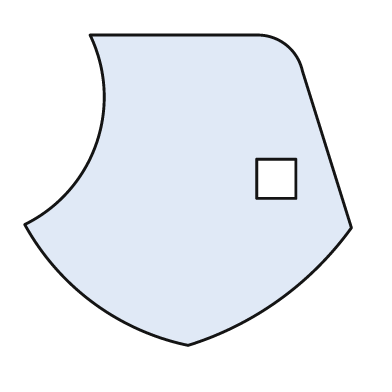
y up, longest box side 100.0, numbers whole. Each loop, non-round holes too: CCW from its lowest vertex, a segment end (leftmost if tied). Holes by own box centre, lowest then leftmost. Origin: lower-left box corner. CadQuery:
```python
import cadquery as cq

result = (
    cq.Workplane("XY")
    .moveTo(50.0, 0.0)
    .threePointArc((78.0, 14.0), (100.0, 36.0))
    .lineTo(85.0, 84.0)
    .threePointArc((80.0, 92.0), (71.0, 95.0))
    .lineTo(20.0, 95.0)
    .threePointArc((22.0, 62.0), (0.0, 37.0))
    .threePointArc((21.0, 13.0), (50.0, 0.0))
    .close()
    .moveTo(71.0, 45.0)
    .lineTo(83.0, 45.0)
    .lineTo(83.0, 57.0)
    .lineTo(71.0, 57.0)
    .close()
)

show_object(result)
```